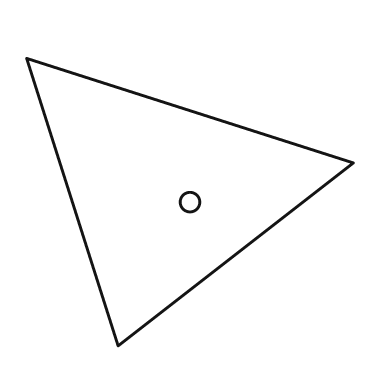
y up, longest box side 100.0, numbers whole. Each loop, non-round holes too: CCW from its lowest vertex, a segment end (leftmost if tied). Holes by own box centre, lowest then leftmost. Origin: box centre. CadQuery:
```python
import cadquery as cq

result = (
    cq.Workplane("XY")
    .moveTo(-22.0, -44.0)
    .lineTo(50.0, 12.0)
    .lineTo(-50.0, 44.0)
    .close()
    .moveTo(0.0, 0.0)
    .circle(3.0)
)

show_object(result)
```